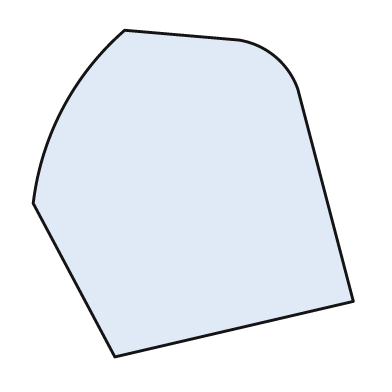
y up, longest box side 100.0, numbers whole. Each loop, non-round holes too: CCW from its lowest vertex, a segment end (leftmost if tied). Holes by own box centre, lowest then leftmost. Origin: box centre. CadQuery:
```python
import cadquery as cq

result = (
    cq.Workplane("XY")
    .moveTo(-24.0, -50.0)
    .lineTo(49.0, -33.0)
    .lineTo(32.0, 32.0)
    .threePointArc((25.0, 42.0), (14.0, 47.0))
    .lineTo(-21.0, 50.0)
    .threePointArc((-40.0, 26.0), (-49.0, -3.0))
    .close()
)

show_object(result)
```